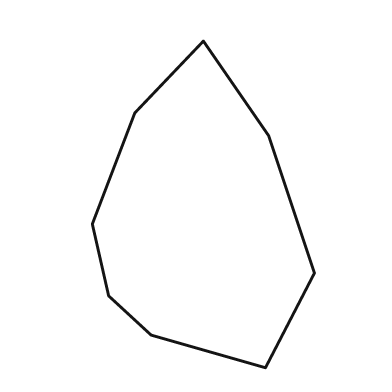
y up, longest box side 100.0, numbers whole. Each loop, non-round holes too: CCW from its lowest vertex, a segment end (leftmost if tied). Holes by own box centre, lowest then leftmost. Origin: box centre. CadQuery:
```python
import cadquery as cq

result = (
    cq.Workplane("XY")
    .moveTo(19.0, -50.0)
    .lineTo(34.0, -21.0)
    .lineTo(20.0, 21.0)
    .lineTo(0.0, 50.0)
    .lineTo(-21.0, 28.0)
    .lineTo(-34.0, -6.0)
    .lineTo(-29.0, -28.0)
    .lineTo(-16.0, -40.0)
    .close()
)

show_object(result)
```